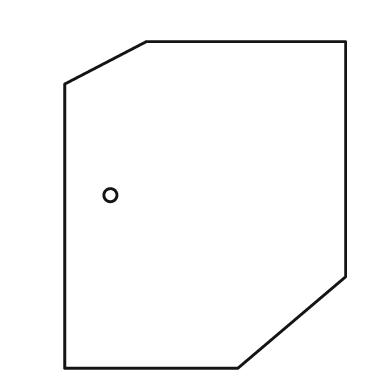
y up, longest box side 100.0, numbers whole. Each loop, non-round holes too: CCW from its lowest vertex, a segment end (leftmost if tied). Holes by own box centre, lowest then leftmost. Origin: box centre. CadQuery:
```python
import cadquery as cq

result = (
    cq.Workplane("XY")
    .moveTo(-43.0, -50.0)
    .lineTo(10.0, -50.0)
    .lineTo(43.0, -22.0)
    .lineTo(43.0, 50.0)
    .lineTo(-18.0, 50.0)
    .lineTo(-43.0, 37.0)
    .close()
    .moveTo(-29.0, 3.0)
    .circle(2.0)
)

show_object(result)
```